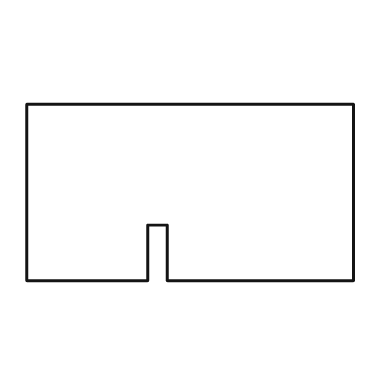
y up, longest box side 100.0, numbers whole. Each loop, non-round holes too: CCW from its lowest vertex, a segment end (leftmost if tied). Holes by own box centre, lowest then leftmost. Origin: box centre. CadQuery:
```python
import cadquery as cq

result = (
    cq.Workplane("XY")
    .moveTo(-50.0, -27.0)
    .lineTo(-13.0, -27.0)
    .lineTo(-13.0, -10.0)
    .lineTo(-7.0, -10.0)
    .lineTo(-7.0, -27.0)
    .lineTo(50.0, -27.0)
    .lineTo(50.0, 27.0)
    .lineTo(-50.0, 27.0)
    .close()
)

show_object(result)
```